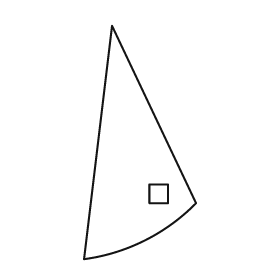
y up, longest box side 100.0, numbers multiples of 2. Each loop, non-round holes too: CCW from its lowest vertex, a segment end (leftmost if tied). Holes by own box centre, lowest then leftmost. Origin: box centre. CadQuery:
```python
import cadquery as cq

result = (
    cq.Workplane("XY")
    .moveTo(-24.0, -50.0)
    .threePointArc((2.0, -42.0), (24.0, -26.0))
    .lineTo(-12.0, 50.0)
    .close()
    .moveTo(4.0, -26.0)
    .lineTo(12.0, -26.0)
    .lineTo(12.0, -18.0)
    .lineTo(4.0, -18.0)
    .close()
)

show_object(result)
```